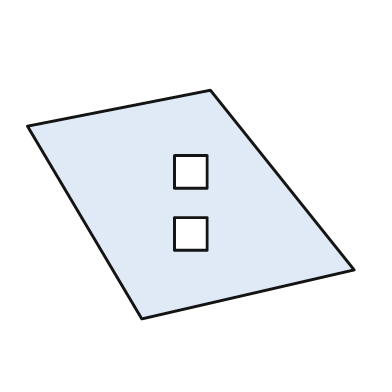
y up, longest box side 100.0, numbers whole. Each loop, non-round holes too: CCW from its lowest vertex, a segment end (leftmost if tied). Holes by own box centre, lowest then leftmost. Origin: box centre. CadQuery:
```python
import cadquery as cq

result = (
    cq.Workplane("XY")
    .moveTo(-15.0, -35.0)
    .lineTo(50.0, -20.0)
    .lineTo(6.0, 35.0)
    .lineTo(-50.0, 24.0)
    .close()
    .moveTo(-5.0, -14.0)
    .lineTo(5.0, -14.0)
    .lineTo(5.0, -4.0)
    .lineTo(-5.0, -4.0)
    .close()
    .moveTo(-5.0, 5.0)
    .lineTo(5.0, 5.0)
    .lineTo(5.0, 15.0)
    .lineTo(-5.0, 15.0)
    .close()
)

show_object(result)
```